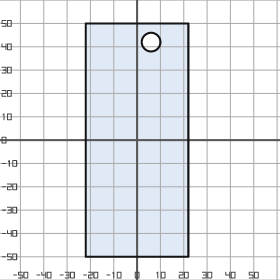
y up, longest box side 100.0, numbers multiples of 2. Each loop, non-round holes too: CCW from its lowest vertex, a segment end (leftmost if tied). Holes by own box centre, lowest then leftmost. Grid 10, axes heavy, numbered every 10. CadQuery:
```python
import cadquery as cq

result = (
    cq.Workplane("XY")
    .moveTo(-22.0, -50.0)
    .lineTo(22.0, -50.0)
    .lineTo(22.0, 50.0)
    .lineTo(-22.0, 50.0)
    .close()
    .moveTo(6.0, 42.0)
    .circle(4.0)
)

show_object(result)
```